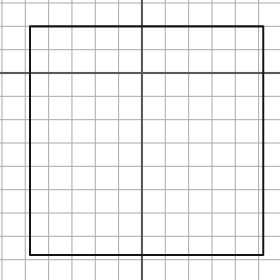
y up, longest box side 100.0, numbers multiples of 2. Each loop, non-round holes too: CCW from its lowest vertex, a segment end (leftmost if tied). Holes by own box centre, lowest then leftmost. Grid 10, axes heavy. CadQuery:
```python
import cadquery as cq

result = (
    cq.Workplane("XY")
    .moveTo(-48.0, -78.0)
    .lineTo(52.0, -78.0)
    .lineTo(52.0, 20.0)
    .lineTo(-48.0, 20.0)
    .close()
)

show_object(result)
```